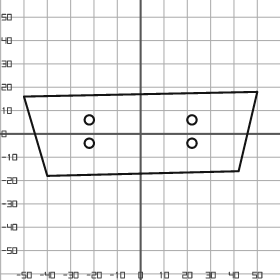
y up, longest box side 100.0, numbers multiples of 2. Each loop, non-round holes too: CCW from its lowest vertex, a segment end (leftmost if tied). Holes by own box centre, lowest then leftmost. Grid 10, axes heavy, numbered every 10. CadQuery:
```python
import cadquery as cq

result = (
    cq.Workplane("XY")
    .moveTo(-40.0, -18.0)
    .lineTo(42.0, -16.0)
    .lineTo(50.0, 18.0)
    .lineTo(-50.0, 16.0)
    .close()
    .moveTo(-22.0, -4.0)
    .circle(2.0)
    .moveTo(22.0, -4.0)
    .circle(2.0)
    .moveTo(-22.0, 6.0)
    .circle(2.0)
    .moveTo(22.0, 6.0)
    .circle(2.0)
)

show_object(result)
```